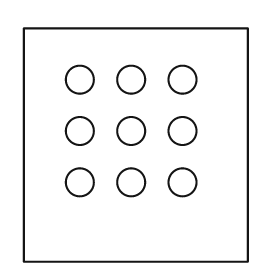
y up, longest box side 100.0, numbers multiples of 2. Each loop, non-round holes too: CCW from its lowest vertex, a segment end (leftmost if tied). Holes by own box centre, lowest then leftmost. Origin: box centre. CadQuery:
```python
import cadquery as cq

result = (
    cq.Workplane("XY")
    .moveTo(-48.0, -50.0)
    .lineTo(48.0, -50.0)
    .lineTo(48.0, 50.0)
    .lineTo(-48.0, 50.0)
    .close()
    .moveTo(-24.0, -16.0)
    .circle(6.0)
    .moveTo(-2.0, -16.0)
    .circle(6.0)
    .moveTo(20.0, -16.0)
    .circle(6.0)
    .moveTo(-24.0, 6.0)
    .circle(6.0)
    .moveTo(-2.0, 6.0)
    .circle(6.0)
    .moveTo(20.0, 6.0)
    .circle(6.0)
    .moveTo(-24.0, 28.0)
    .circle(6.0)
    .moveTo(-2.0, 28.0)
    .circle(6.0)
    .moveTo(20.0, 28.0)
    .circle(6.0)
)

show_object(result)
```